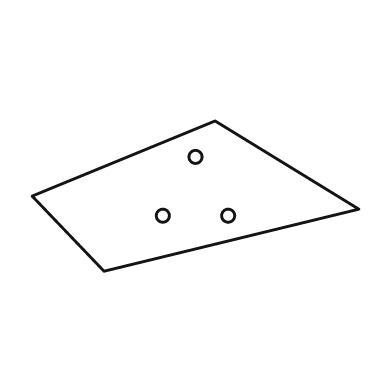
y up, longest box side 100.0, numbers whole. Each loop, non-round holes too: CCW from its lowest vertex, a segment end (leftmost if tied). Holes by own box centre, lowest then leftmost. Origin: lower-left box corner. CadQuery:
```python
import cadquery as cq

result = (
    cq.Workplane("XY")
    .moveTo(22.0, 0.0)
    .lineTo(100.0, 19.0)
    .lineTo(56.0, 46.0)
    .lineTo(0.0, 23.0)
    .close()
    .moveTo(40.0, 17.0)
    .circle(2.0)
    .moveTo(60.0, 17.0)
    .circle(2.0)
    .moveTo(50.0, 35.0)
    .circle(2.0)
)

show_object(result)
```